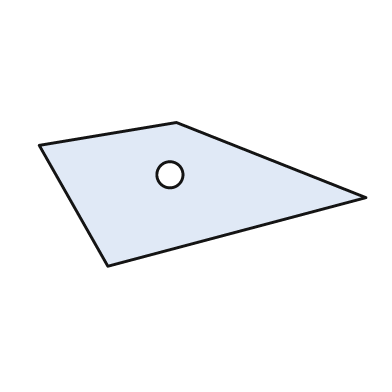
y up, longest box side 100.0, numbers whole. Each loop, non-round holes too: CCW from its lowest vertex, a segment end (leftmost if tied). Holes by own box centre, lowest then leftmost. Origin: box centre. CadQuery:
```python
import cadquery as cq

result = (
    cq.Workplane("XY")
    .moveTo(-29.0, -22.0)
    .lineTo(50.0, -1.0)
    .lineTo(-8.0, 22.0)
    .lineTo(-50.0, 15.0)
    .close()
    .moveTo(-10.0, 6.0)
    .circle(4.0)
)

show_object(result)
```